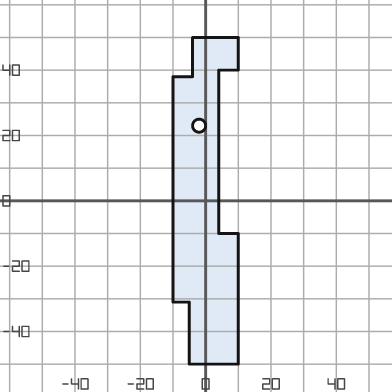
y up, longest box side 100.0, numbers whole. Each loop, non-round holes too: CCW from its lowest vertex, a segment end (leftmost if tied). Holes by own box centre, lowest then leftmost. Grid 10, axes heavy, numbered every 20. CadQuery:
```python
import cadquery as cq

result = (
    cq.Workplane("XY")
    .moveTo(-5.0, -50.0)
    .lineTo(10.0, -50.0)
    .lineTo(10.0, -10.0)
    .lineTo(4.0, -10.0)
    .lineTo(4.0, 40.0)
    .lineTo(10.0, 40.0)
    .lineTo(10.0, 50.0)
    .lineTo(-4.0, 50.0)
    .lineTo(-4.0, 38.0)
    .lineTo(-10.0, 38.0)
    .lineTo(-10.0, -31.0)
    .lineTo(-5.0, -31.0)
    .close()
    .moveTo(-2.0, 23.0)
    .circle(2.0)
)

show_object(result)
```